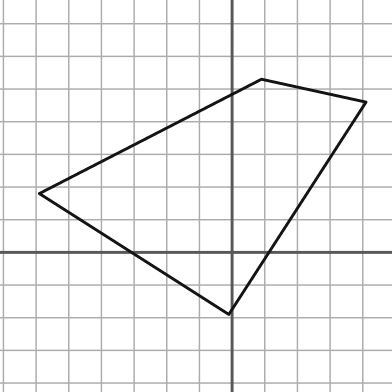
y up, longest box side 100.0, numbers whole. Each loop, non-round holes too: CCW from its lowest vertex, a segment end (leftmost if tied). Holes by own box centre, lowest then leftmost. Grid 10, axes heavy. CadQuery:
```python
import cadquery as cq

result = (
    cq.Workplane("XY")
    .moveTo(-1.0, -19.0)
    .lineTo(41.0, 46.0)
    .lineTo(9.0, 53.0)
    .lineTo(-59.0, 18.0)
    .close()
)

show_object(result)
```